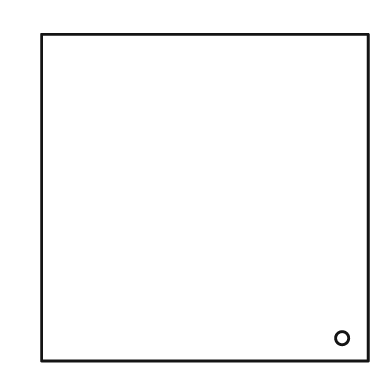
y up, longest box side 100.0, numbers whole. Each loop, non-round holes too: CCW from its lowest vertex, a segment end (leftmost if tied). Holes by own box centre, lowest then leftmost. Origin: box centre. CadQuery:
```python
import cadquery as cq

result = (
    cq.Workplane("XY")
    .moveTo(-50.0, -50.0)
    .lineTo(50.0, -50.0)
    .lineTo(50.0, 50.0)
    .lineTo(-50.0, 50.0)
    .close()
    .moveTo(42.0, -43.0)
    .circle(2.0)
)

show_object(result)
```